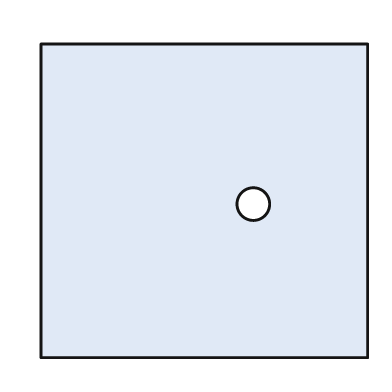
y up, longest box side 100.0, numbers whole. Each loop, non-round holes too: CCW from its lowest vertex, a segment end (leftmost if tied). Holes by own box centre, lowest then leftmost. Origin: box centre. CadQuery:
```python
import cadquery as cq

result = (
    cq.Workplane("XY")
    .moveTo(-50.0, -48.0)
    .lineTo(50.0, -48.0)
    .lineTo(50.0, 48.0)
    .lineTo(-50.0, 48.0)
    .close()
    .moveTo(15.0, -1.0)
    .circle(5.0)
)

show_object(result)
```